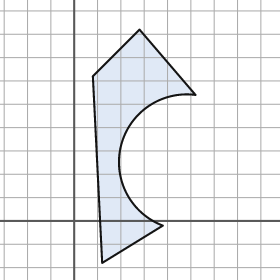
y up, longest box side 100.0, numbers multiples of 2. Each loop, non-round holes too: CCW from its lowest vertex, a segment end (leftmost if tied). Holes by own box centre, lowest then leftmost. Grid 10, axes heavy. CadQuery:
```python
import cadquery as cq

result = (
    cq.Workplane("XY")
    .moveTo(12.0, -18.0)
    .lineTo(38.0, -2.0)
    .threePointArc((20.0, 32.0), (52.0, 54.0))
    .lineTo(28.0, 82.0)
    .lineTo(8.0, 62.0)
    .close()
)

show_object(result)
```